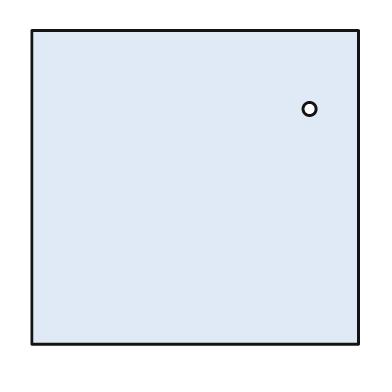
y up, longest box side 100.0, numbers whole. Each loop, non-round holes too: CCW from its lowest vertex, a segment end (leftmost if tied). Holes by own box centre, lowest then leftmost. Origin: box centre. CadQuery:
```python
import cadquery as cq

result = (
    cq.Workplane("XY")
    .moveTo(-50.0, -48.0)
    .lineTo(50.0, -48.0)
    .lineTo(50.0, 48.0)
    .lineTo(-50.0, 48.0)
    .close()
    .moveTo(35.0, 24.0)
    .circle(2.0)
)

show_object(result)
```